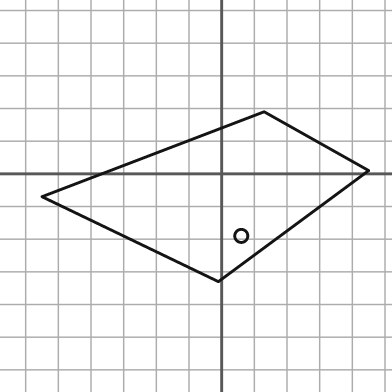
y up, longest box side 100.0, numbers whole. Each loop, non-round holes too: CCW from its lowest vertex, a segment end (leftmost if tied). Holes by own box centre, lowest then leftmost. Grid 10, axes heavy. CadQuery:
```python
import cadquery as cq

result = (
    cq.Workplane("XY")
    .moveTo(-1.0, -33.0)
    .lineTo(45.0, 1.0)
    .lineTo(13.0, 19.0)
    .lineTo(-55.0, -7.0)
    .close()
    .moveTo(6.0, -19.0)
    .circle(2.0)
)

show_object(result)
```